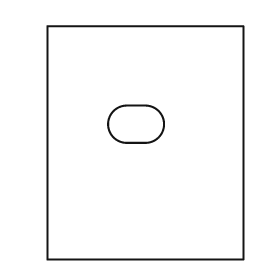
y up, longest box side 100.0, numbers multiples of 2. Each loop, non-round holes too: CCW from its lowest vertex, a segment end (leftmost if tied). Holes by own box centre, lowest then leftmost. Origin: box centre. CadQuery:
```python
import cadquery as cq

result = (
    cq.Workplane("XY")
    .moveTo(-42.0, -50.0)
    .lineTo(42.0, -50.0)
    .lineTo(42.0, 50.0)
    .lineTo(-42.0, 50.0)
    .close()
    .moveTo(-8.0, 0.0)
    .lineTo(0.0, 0.0)
    .threePointArc((8.0, 8.0), (0.0, 16.0))
    .lineTo(-8.0, 16.0)
    .threePointArc((-16.0, 8.0), (-8.0, 0.0))
    .close()
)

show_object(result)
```